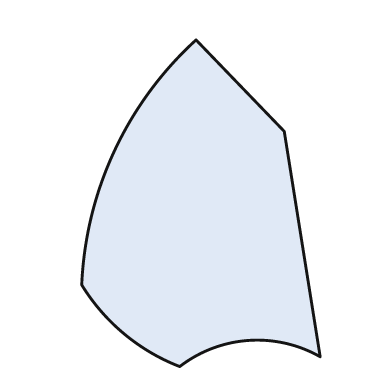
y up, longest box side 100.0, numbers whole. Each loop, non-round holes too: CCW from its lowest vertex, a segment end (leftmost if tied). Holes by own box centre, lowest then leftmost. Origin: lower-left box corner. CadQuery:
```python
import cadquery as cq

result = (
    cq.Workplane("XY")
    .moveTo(30.0, 0.0)
    .threePointArc((51.0, 8.0), (73.0, 3.0))
    .lineTo(62.0, 72.0)
    .lineTo(35.0, 100.0)
    .threePointArc((10.0, 66.0), (0.0, 25.0))
    .threePointArc((13.0, 10.0), (30.0, 0.0))
    .close()
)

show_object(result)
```